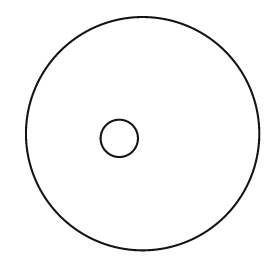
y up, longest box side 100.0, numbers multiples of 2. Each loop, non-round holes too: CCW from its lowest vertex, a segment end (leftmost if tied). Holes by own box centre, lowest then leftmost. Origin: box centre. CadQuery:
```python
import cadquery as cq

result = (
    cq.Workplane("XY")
    .moveTo(0.0, 0.0)
    .circle(50.0)
    .moveTo(-10.0, -2.0)
    .circle(8.0)
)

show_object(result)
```